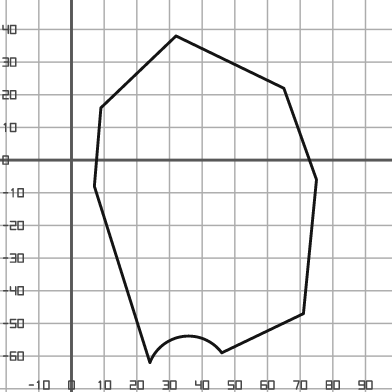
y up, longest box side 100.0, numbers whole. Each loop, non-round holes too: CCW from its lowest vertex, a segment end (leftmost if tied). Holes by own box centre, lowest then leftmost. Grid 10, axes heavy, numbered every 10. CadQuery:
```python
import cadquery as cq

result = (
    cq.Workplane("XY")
    .moveTo(24.0, -62.0)
    .threePointArc((34.0, -54.0), (46.0, -59.0))
    .lineTo(71.0, -47.0)
    .lineTo(75.0, -6.0)
    .lineTo(65.0, 22.0)
    .lineTo(32.0, 38.0)
    .lineTo(9.0, 16.0)
    .lineTo(7.0, -8.0)
    .close()
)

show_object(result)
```